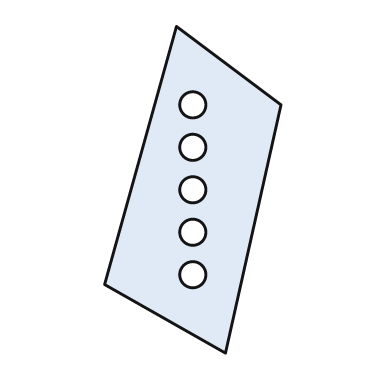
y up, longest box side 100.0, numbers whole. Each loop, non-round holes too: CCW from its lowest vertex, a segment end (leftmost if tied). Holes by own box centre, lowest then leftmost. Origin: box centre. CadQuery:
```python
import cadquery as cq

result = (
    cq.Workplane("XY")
    .moveTo(10.0, -50.0)
    .lineTo(27.0, 26.0)
    .lineTo(-5.0, 50.0)
    .lineTo(-27.0, -29.0)
    .close()
    .moveTo(0.0, -26.0)
    .circle(4.0)
    .moveTo(0.0, -13.0)
    .circle(4.0)
    .moveTo(0.0, 0.0)
    .circle(4.0)
    .moveTo(0.0, 13.0)
    .circle(4.0)
    .moveTo(0.0, 26.0)
    .circle(4.0)
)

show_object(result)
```